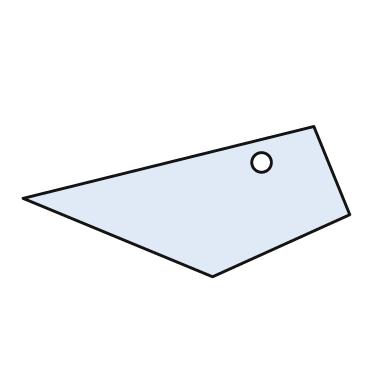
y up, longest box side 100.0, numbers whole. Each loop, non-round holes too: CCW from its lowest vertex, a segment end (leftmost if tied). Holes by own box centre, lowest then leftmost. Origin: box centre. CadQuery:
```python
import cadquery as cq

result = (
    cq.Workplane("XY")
    .moveTo(8.0, -23.0)
    .lineTo(50.0, -4.0)
    .lineTo(39.0, 23.0)
    .lineTo(-50.0, 1.0)
    .close()
    .moveTo(23.0, 12.0)
    .circle(3.0)
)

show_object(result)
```